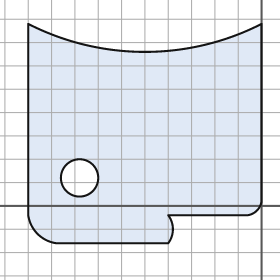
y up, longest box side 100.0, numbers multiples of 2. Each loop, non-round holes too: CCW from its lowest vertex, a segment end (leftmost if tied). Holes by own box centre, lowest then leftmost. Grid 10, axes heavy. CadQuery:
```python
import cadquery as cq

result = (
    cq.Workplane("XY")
    .moveTo(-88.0, -16.0)
    .lineTo(-40.0, -16.0)
    .threePointArc((-38.0, -10.0), (-40.0, -4.0))
    .lineTo(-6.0, -4.0)
    .threePointArc((-2.0, -2.0), (0.0, 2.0))
    .lineTo(0.0, 78.0)
    .threePointArc((-50.0, 66.0), (-100.0, 78.0))
    .lineTo(-100.0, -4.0)
    .threePointArc((-96.0, -12.0), (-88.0, -16.0))
    .close()
    .moveTo(-78.0, 12.0)
    .circle(8.0)
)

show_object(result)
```